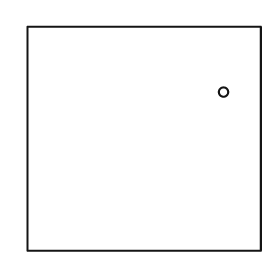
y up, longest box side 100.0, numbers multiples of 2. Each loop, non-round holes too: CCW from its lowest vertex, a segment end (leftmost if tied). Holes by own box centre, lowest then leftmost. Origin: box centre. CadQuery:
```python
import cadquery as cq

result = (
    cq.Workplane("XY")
    .moveTo(-50.0, -48.0)
    .lineTo(50.0, -48.0)
    .lineTo(50.0, 48.0)
    .lineTo(-50.0, 48.0)
    .close()
    .moveTo(34.0, 20.0)
    .circle(2.0)
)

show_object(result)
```